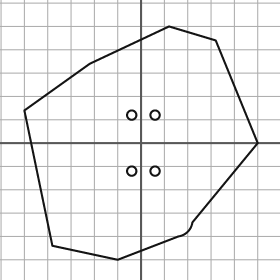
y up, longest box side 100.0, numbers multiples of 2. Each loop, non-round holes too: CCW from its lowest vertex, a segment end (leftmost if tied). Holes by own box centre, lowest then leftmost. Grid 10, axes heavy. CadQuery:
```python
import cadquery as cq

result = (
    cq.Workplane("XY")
    .moveTo(-10.0, -50.0)
    .lineTo(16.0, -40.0)
    .threePointArc((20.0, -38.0), (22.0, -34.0))
    .lineTo(50.0, 0.0)
    .lineTo(32.0, 44.0)
    .lineTo(12.0, 50.0)
    .lineTo(-22.0, 34.0)
    .lineTo(-50.0, 14.0)
    .lineTo(-38.0, -44.0)
    .close()
    .moveTo(-4.0, -12.0)
    .circle(2.0)
    .moveTo(6.0, -12.0)
    .circle(2.0)
    .moveTo(-4.0, 12.0)
    .circle(2.0)
    .moveTo(6.0, 12.0)
    .circle(2.0)
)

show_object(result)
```